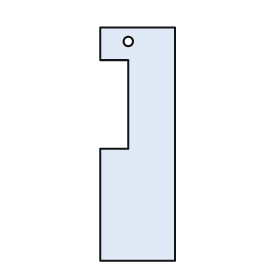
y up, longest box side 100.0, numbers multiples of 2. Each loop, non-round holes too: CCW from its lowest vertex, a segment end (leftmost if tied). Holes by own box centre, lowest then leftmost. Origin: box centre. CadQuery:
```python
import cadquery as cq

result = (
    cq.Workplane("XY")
    .moveTo(-16.0, -50.0)
    .lineTo(16.0, -50.0)
    .lineTo(16.0, 50.0)
    .lineTo(-16.0, 50.0)
    .lineTo(-16.0, 36.0)
    .lineTo(-4.0, 36.0)
    .lineTo(-4.0, -2.0)
    .lineTo(-16.0, -2.0)
    .close()
    .moveTo(-4.0, 44.0)
    .circle(2.0)
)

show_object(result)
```